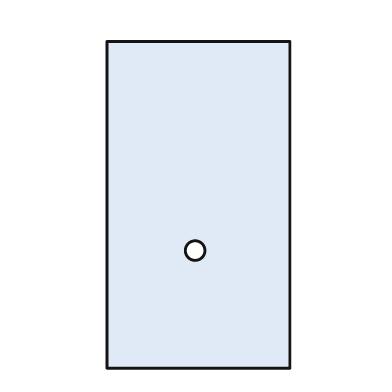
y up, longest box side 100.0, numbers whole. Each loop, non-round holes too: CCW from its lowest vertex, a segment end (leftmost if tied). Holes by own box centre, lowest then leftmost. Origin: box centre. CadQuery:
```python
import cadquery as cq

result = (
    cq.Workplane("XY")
    .moveTo(-28.0, -50.0)
    .lineTo(28.0, -50.0)
    .lineTo(28.0, 50.0)
    .lineTo(-28.0, 50.0)
    .close()
    .moveTo(-1.0, -14.0)
    .circle(3.0)
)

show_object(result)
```